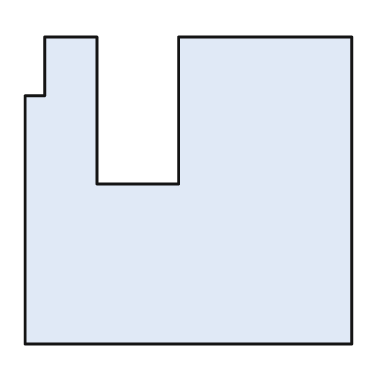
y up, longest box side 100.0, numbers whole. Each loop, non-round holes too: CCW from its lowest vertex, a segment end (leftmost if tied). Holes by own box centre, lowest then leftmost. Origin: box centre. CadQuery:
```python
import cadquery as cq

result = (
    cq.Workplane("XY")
    .moveTo(-50.0, -47.0)
    .lineTo(50.0, -47.0)
    .lineTo(50.0, 47.0)
    .lineTo(-3.0, 47.0)
    .lineTo(-3.0, 2.0)
    .lineTo(-28.0, 2.0)
    .lineTo(-28.0, 47.0)
    .lineTo(-44.0, 47.0)
    .lineTo(-44.0, 29.0)
    .lineTo(-50.0, 29.0)
    .close()
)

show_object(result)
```